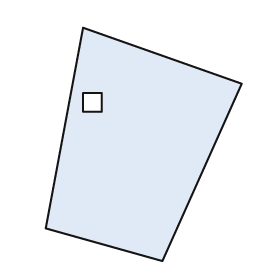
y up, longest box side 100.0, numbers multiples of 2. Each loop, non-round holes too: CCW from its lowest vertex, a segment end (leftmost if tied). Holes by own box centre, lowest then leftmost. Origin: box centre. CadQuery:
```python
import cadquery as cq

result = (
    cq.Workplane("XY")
    .moveTo(8.0, -50.0)
    .lineTo(42.0, 26.0)
    .lineTo(-26.0, 50.0)
    .lineTo(-42.0, -36.0)
    .close()
    .moveTo(-26.0, 14.0)
    .lineTo(-18.0, 14.0)
    .lineTo(-18.0, 22.0)
    .lineTo(-26.0, 22.0)
    .close()
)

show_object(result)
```